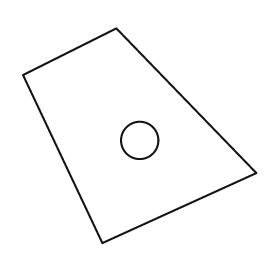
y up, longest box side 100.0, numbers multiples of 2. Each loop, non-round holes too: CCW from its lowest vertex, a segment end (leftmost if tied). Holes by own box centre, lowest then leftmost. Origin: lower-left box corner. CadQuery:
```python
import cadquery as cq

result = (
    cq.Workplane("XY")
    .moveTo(34.0, 0.0)
    .lineTo(100.0, 30.0)
    .lineTo(40.0, 92.0)
    .lineTo(0.0, 72.0)
    .close()
    .moveTo(50.0, 44.0)
    .circle(8.0)
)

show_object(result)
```